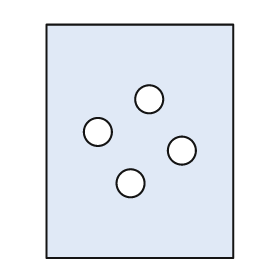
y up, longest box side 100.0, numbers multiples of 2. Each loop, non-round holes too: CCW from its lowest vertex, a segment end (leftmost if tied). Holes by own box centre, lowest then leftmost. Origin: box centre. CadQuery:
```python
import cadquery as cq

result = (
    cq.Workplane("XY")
    .moveTo(-40.0, -50.0)
    .lineTo(40.0, -50.0)
    .lineTo(40.0, 50.0)
    .lineTo(-40.0, 50.0)
    .close()
    .moveTo(-4.0, -18.0)
    .circle(6.0)
    .moveTo(18.0, -4.0)
    .circle(6.0)
    .moveTo(-18.0, 4.0)
    .circle(6.0)
    .moveTo(4.0, 18.0)
    .circle(6.0)
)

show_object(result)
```